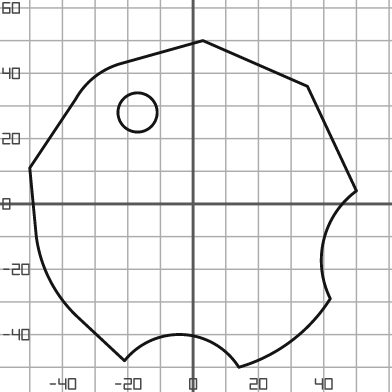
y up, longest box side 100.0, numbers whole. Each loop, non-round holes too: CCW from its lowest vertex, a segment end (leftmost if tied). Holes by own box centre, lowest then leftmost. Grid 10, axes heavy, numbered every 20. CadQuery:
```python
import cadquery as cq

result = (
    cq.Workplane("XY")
    .moveTo(14.0, -50.0)
    .threePointArc((30.0, -42.0), (42.0, -29.0))
    .threePointArc((40.0, -11.0), (50.0, 4.0))
    .lineTo(35.0, 36.0)
    .lineTo(3.0, 50.0)
    .lineTo(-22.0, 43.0)
    .threePointArc((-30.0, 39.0), (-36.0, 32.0))
    .lineTo(-50.0, 11.0)
    .lineTo(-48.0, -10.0)
    .threePointArc((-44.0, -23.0), (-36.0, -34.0))
    .lineTo(-21.0, -48.0)
    .threePointArc((-3.0, -40.0), (14.0, -50.0))
    .close()
    .moveTo(-17.0, 28.0)
    .circle(6.0)
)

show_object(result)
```